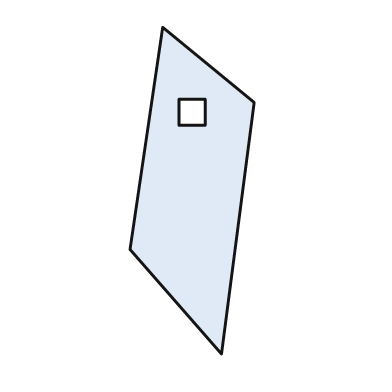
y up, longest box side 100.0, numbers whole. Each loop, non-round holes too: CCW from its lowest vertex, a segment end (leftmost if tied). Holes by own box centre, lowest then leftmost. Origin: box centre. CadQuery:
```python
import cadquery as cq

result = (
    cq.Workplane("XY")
    .moveTo(9.0, -50.0)
    .lineTo(19.0, 27.0)
    .lineTo(-9.0, 50.0)
    .lineTo(-19.0, -18.0)
    .close()
    .moveTo(-4.0, 20.0)
    .lineTo(4.0, 20.0)
    .lineTo(4.0, 28.0)
    .lineTo(-4.0, 28.0)
    .close()
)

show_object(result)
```